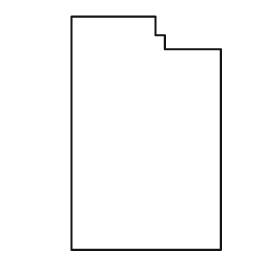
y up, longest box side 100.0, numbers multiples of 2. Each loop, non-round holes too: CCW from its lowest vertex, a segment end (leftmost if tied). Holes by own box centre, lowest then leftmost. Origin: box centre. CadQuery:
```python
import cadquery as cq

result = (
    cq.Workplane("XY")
    .moveTo(-32.0, -50.0)
    .lineTo(32.0, -50.0)
    .lineTo(32.0, 36.0)
    .lineTo(8.0, 36.0)
    .lineTo(8.0, 42.0)
    .lineTo(4.0, 42.0)
    .lineTo(4.0, 50.0)
    .lineTo(-32.0, 50.0)
    .close()
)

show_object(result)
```